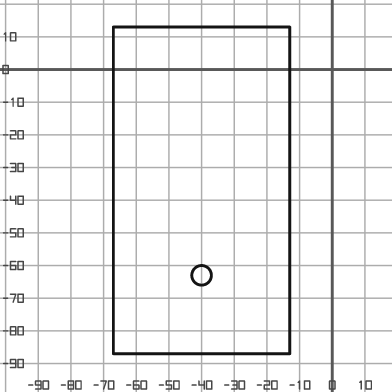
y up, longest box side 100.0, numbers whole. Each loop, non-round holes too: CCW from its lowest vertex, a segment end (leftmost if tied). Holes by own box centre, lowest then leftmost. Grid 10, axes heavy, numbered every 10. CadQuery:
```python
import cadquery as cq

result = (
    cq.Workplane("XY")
    .moveTo(-67.0, -87.0)
    .lineTo(-13.0, -87.0)
    .lineTo(-13.0, 13.0)
    .lineTo(-67.0, 13.0)
    .close()
    .moveTo(-40.0, -63.0)
    .circle(3.0)
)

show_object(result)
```